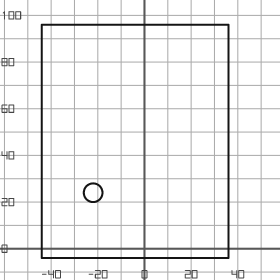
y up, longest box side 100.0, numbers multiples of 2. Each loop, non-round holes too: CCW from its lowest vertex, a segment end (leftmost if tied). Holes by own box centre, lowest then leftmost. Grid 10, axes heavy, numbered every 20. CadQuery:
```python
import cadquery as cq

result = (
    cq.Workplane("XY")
    .moveTo(-44.0, -4.0)
    .lineTo(36.0, -4.0)
    .lineTo(36.0, 96.0)
    .lineTo(-44.0, 96.0)
    .close()
    .moveTo(-22.0, 24.0)
    .circle(4.0)
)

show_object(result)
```